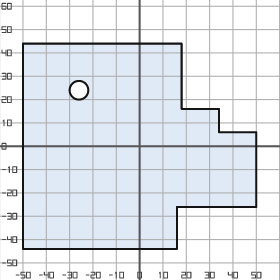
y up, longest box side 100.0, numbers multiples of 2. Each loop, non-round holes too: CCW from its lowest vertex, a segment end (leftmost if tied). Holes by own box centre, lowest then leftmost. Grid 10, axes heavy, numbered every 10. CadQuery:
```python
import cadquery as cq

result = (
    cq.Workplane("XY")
    .moveTo(-50.0, -44.0)
    .lineTo(16.0, -44.0)
    .lineTo(16.0, -26.0)
    .lineTo(50.0, -26.0)
    .lineTo(50.0, 6.0)
    .lineTo(34.0, 6.0)
    .lineTo(34.0, 16.0)
    .lineTo(18.0, 16.0)
    .lineTo(18.0, 44.0)
    .lineTo(-50.0, 44.0)
    .close()
    .moveTo(-26.0, 24.0)
    .circle(4.0)
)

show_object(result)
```